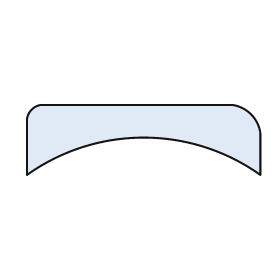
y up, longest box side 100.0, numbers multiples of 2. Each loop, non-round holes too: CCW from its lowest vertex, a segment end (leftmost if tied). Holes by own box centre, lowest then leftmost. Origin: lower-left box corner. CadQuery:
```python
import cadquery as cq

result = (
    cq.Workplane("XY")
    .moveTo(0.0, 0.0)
    .threePointArc((50.0, 16.0), (100.0, 0.0))
    .lineTo(100.0, 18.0)
    .threePointArc((96.0, 26.0), (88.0, 30.0))
    .lineTo(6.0, 30.0)
    .threePointArc((2.0, 28.0), (0.0, 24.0))
    .close()
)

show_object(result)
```